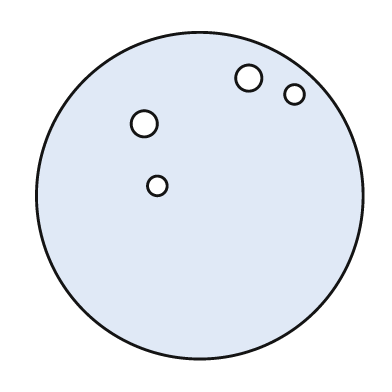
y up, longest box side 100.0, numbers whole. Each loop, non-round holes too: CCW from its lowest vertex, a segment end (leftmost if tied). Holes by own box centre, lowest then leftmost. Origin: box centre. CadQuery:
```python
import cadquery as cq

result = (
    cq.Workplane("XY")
    .moveTo(0.0, 0.0)
    .circle(50.0)
    .moveTo(-13.0, 3.0)
    .circle(3.0)
    .moveTo(-17.0, 22.0)
    .circle(4.0)
    .moveTo(29.0, 31.0)
    .circle(3.0)
    .moveTo(15.0, 36.0)
    .circle(4.0)
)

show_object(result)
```